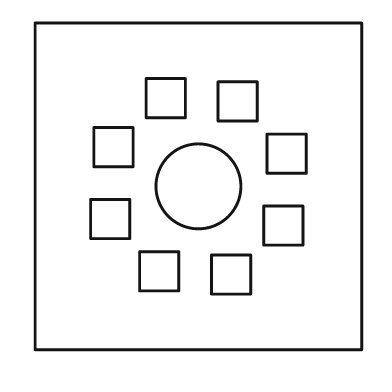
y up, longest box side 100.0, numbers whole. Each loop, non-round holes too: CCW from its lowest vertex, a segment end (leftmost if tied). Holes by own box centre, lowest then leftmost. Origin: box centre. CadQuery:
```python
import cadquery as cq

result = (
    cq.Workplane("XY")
    .moveTo(-50.0, -50.0)
    .lineTo(50.0, -50.0)
    .lineTo(50.0, 50.0)
    .lineTo(-50.0, 50.0)
    .close()
    .moveTo(4.0, -33.0)
    .lineTo(16.0, -33.0)
    .lineTo(16.0, -21.0)
    .lineTo(4.0, -21.0)
    .close()
    .moveTo(-18.0, -32.0)
    .lineTo(-6.0, -32.0)
    .lineTo(-6.0, -20.0)
    .lineTo(-18.0, -20.0)
    .close()
    .moveTo(20.0, -18.0)
    .lineTo(32.0, -18.0)
    .lineTo(32.0, -6.0)
    .lineTo(20.0, -6.0)
    .close()
    .moveTo(-33.0, -16.0)
    .lineTo(-21.0, -16.0)
    .lineTo(-21.0, -4.0)
    .lineTo(-33.0, -4.0)
    .close()
    .moveTo(0.0, 0.0)
    .circle(13.0)
    .moveTo(21.0, 4.0)
    .lineTo(33.0, 4.0)
    .lineTo(33.0, 16.0)
    .lineTo(21.0, 16.0)
    .close()
    .moveTo(-32.0, 6.0)
    .lineTo(-20.0, 6.0)
    .lineTo(-20.0, 18.0)
    .lineTo(-32.0, 18.0)
    .close()
    .moveTo(6.0, 20.0)
    .lineTo(18.0, 20.0)
    .lineTo(18.0, 32.0)
    .lineTo(6.0, 32.0)
    .close()
    .moveTo(-16.0, 21.0)
    .lineTo(-4.0, 21.0)
    .lineTo(-4.0, 33.0)
    .lineTo(-16.0, 33.0)
    .close()
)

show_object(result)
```